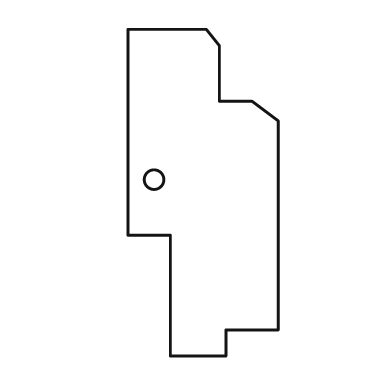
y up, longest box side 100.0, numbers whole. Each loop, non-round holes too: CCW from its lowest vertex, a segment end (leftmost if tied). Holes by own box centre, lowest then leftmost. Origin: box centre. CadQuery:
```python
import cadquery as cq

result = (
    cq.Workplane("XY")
    .moveTo(-10.0, -50.0)
    .lineTo(7.0, -50.0)
    .lineTo(7.0, -42.0)
    .lineTo(23.0, -42.0)
    .lineTo(23.0, 22.0)
    .lineTo(15.0, 28.0)
    .lineTo(5.0, 28.0)
    .lineTo(5.0, 45.0)
    .lineTo(1.0, 50.0)
    .lineTo(-23.0, 50.0)
    .lineTo(-23.0, -13.0)
    .lineTo(-10.0, -13.0)
    .close()
    .moveTo(-15.0, 4.0)
    .circle(3.0)
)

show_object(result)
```